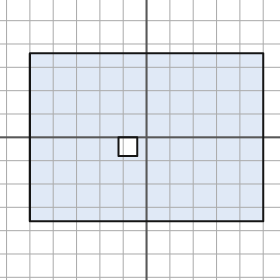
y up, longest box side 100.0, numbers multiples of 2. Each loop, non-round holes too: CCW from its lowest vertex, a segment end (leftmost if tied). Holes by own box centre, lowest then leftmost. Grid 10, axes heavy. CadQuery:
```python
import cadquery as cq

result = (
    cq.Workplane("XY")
    .moveTo(-50.0, -36.0)
    .lineTo(50.0, -36.0)
    .lineTo(50.0, 36.0)
    .lineTo(-50.0, 36.0)
    .close()
    .moveTo(-12.0, -8.0)
    .lineTo(-4.0, -8.0)
    .lineTo(-4.0, 0.0)
    .lineTo(-12.0, 0.0)
    .close()
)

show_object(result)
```